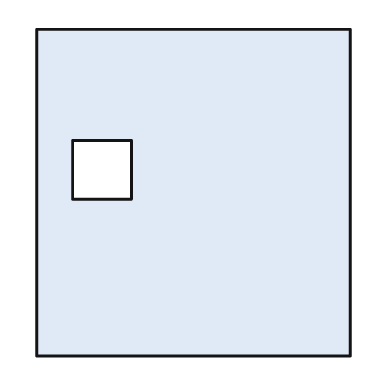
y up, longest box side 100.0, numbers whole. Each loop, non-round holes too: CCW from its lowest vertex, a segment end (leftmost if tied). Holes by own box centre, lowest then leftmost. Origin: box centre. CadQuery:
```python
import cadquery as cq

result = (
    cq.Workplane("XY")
    .moveTo(-48.0, -50.0)
    .lineTo(48.0, -50.0)
    .lineTo(48.0, 50.0)
    .lineTo(-48.0, 50.0)
    .close()
    .moveTo(-37.0, -2.0)
    .lineTo(-19.0, -2.0)
    .lineTo(-19.0, 16.0)
    .lineTo(-37.0, 16.0)
    .close()
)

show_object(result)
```